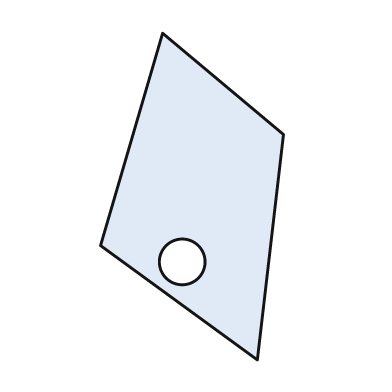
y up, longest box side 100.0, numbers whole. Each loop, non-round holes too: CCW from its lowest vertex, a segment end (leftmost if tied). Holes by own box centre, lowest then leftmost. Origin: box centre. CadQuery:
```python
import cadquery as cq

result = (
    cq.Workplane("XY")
    .moveTo(20.0, -50.0)
    .lineTo(28.0, 19.0)
    .lineTo(-9.0, 50.0)
    .lineTo(-28.0, -15.0)
    .close()
    .moveTo(-3.0, -20.0)
    .circle(7.0)
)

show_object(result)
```